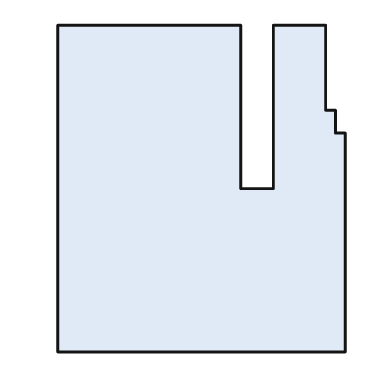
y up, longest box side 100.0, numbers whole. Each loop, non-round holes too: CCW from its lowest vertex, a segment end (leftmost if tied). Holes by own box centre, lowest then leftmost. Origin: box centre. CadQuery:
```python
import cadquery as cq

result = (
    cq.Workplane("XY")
    .moveTo(-44.0, -50.0)
    .lineTo(44.0, -50.0)
    .lineTo(44.0, 17.0)
    .lineTo(41.0, 17.0)
    .lineTo(41.0, 24.0)
    .lineTo(38.0, 24.0)
    .lineTo(38.0, 50.0)
    .lineTo(22.0, 50.0)
    .lineTo(22.0, 0.0)
    .lineTo(12.0, 0.0)
    .lineTo(12.0, 50.0)
    .lineTo(-44.0, 50.0)
    .close()
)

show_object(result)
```